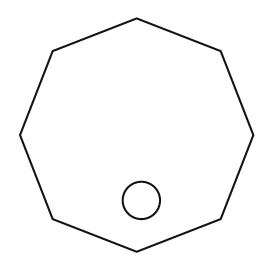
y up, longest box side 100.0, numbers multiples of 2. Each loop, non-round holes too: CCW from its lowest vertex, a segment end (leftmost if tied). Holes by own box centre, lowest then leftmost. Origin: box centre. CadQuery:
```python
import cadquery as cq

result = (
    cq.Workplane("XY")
    .moveTo(0.0, -50.0)
    .lineTo(36.0, -36.0)
    .lineTo(50.0, 0.0)
    .lineTo(36.0, 36.0)
    .lineTo(0.0, 50.0)
    .lineTo(-36.0, 36.0)
    .lineTo(-50.0, 0.0)
    .lineTo(-36.0, -36.0)
    .close()
    .moveTo(2.0, -28.0)
    .circle(8.0)
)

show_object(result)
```